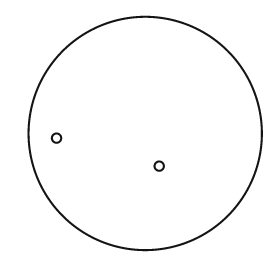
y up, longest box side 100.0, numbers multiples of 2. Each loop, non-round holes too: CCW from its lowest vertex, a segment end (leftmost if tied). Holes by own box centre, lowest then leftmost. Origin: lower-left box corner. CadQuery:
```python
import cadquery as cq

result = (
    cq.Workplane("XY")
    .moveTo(50.0, 50.0)
    .circle(50.0)
    .moveTo(56.0, 36.0)
    .circle(2.0)
    .moveTo(12.0, 48.0)
    .circle(2.0)
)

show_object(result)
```